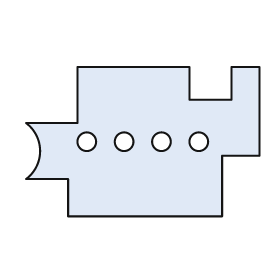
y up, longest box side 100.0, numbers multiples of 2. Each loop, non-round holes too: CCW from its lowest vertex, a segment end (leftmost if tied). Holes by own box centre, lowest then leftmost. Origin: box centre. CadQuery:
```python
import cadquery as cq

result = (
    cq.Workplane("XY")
    .moveTo(-32.0, -32.0)
    .lineTo(34.0, -32.0)
    .lineTo(34.0, -6.0)
    .lineTo(50.0, -6.0)
    .lineTo(50.0, 32.0)
    .lineTo(38.0, 32.0)
    .lineTo(38.0, 18.0)
    .lineTo(20.0, 18.0)
    .lineTo(20.0, 32.0)
    .lineTo(-28.0, 32.0)
    .lineTo(-28.0, 8.0)
    .lineTo(-50.0, 8.0)
    .threePointArc((-44.0, -4.0), (-50.0, -16.0))
    .lineTo(-32.0, -16.0)
    .close()
    .moveTo(-24.0, 0.0)
    .circle(4.0)
    .moveTo(-8.0, 0.0)
    .circle(4.0)
    .moveTo(8.0, 0.0)
    .circle(4.0)
    .moveTo(24.0, 0.0)
    .circle(4.0)
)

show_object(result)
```